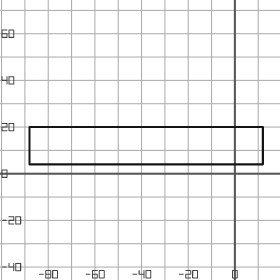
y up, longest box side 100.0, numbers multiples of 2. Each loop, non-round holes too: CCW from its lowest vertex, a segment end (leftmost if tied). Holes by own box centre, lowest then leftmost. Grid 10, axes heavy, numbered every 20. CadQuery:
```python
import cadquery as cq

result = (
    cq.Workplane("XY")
    .moveTo(-88.0, 4.0)
    .lineTo(12.0, 4.0)
    .lineTo(12.0, 20.0)
    .lineTo(-88.0, 20.0)
    .close()
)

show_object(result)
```